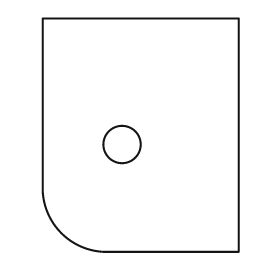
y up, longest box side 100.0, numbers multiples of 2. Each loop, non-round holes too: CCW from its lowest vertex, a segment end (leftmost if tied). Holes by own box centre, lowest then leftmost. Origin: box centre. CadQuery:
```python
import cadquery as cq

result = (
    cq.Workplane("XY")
    .moveTo(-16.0, -50.0)
    .lineTo(42.0, -50.0)
    .lineTo(42.0, 50.0)
    .lineTo(-42.0, 50.0)
    .lineTo(-42.0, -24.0)
    .threePointArc((-34.0, -42.0), (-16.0, -50.0))
    .close()
    .moveTo(-8.0, -4.0)
    .circle(8.0)
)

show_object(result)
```